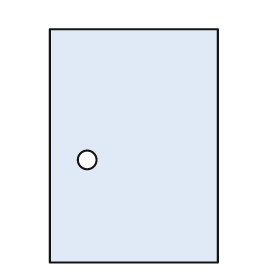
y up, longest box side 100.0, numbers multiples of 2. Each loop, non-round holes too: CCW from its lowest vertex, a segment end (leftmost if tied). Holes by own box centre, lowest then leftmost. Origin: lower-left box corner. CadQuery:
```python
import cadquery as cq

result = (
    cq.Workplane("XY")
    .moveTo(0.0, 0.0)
    .lineTo(72.0, 0.0)
    .lineTo(72.0, 100.0)
    .lineTo(0.0, 100.0)
    .close()
    .moveTo(16.0, 44.0)
    .circle(4.0)
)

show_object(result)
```